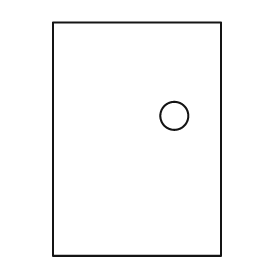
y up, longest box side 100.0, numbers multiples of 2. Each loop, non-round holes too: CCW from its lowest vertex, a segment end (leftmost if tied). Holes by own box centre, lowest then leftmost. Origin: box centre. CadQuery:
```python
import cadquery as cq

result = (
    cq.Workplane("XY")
    .moveTo(-36.0, -50.0)
    .lineTo(36.0, -50.0)
    .lineTo(36.0, 50.0)
    .lineTo(-36.0, 50.0)
    .close()
    .moveTo(16.0, 10.0)
    .circle(6.0)
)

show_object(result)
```